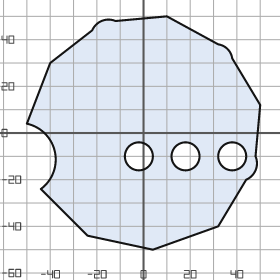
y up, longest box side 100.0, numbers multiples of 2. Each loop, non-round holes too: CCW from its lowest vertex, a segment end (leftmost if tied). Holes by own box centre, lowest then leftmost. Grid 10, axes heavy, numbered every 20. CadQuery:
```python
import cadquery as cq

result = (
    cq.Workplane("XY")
    .moveTo(4.0, -50.0)
    .lineTo(32.0, -40.0)
    .lineTo(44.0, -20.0)
    .threePointArc((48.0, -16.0), (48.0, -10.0))
    .lineTo(50.0, 12.0)
    .lineTo(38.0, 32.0)
    .threePointArc((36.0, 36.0), (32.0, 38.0))
    .lineTo(10.0, 50.0)
    .lineTo(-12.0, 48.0)
    .threePointArc((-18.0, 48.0), (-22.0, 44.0))
    .lineTo(-40.0, 30.0)
    .lineTo(-50.0, 4.0)
    .threePointArc((-38.0, -8.0), (-44.0, -24.0))
    .lineTo(-24.0, -44.0)
    .close()
    .moveTo(-2.0, -10.0)
    .circle(6.0)
    .moveTo(18.0, -10.0)
    .circle(6.0)
    .moveTo(38.0, -10.0)
    .circle(6.0)
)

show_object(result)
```